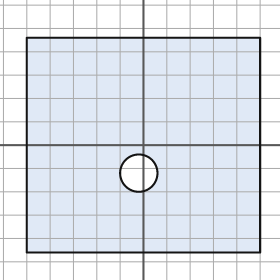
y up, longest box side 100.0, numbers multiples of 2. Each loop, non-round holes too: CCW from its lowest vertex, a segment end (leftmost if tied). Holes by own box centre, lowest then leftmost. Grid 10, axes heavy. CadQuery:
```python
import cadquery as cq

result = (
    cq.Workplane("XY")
    .moveTo(-50.0, -46.0)
    .lineTo(50.0, -46.0)
    .lineTo(50.0, 46.0)
    .lineTo(-50.0, 46.0)
    .close()
    .moveTo(-2.0, -12.0)
    .circle(8.0)
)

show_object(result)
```